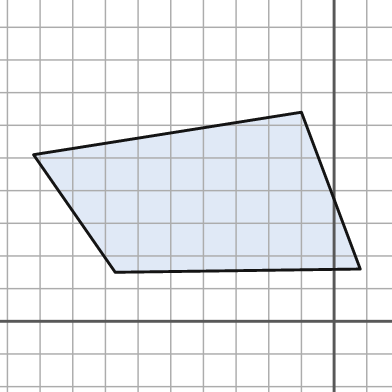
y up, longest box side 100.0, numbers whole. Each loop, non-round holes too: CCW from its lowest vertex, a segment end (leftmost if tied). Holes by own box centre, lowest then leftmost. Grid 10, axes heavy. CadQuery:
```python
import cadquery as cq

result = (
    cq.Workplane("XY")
    .moveTo(-67.0, 15.0)
    .lineTo(8.0, 16.0)
    .lineTo(-10.0, 64.0)
    .lineTo(-92.0, 51.0)
    .close()
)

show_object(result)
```